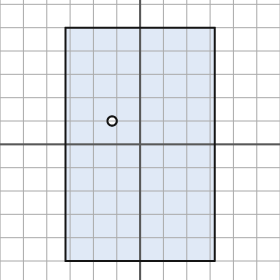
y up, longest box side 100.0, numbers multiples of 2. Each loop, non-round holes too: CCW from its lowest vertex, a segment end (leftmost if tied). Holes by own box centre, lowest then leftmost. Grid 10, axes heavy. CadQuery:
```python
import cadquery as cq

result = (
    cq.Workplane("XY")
    .moveTo(-32.0, -50.0)
    .lineTo(32.0, -50.0)
    .lineTo(32.0, 50.0)
    .lineTo(-32.0, 50.0)
    .close()
    .moveTo(-12.0, 10.0)
    .circle(2.0)
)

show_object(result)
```